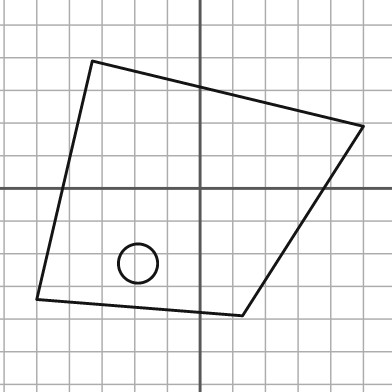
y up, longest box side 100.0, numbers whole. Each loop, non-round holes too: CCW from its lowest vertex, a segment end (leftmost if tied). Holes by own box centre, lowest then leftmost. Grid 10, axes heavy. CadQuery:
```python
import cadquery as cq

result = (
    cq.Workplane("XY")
    .moveTo(13.0, -39.0)
    .lineTo(50.0, 19.0)
    .lineTo(-33.0, 39.0)
    .lineTo(-50.0, -34.0)
    .close()
    .moveTo(-19.0, -23.0)
    .circle(6.0)
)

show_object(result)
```